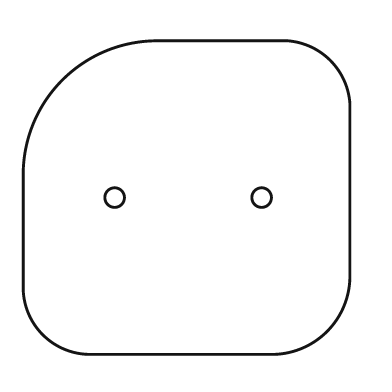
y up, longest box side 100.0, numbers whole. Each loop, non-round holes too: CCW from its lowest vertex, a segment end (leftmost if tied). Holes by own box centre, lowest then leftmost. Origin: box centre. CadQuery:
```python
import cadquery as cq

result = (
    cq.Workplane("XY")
    .moveTo(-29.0, -48.0)
    .lineTo(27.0, -48.0)
    .threePointArc((43.0, -41.0), (50.0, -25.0))
    .lineTo(50.0, 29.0)
    .threePointArc((44.0, 42.0), (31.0, 48.0))
    .lineTo(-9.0, 48.0)
    .threePointArc((-38.0, 36.0), (-50.0, 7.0))
    .lineTo(-50.0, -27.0)
    .threePointArc((-44.0, -42.0), (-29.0, -48.0))
    .close()
    .moveTo(-22.0, 0.0)
    .circle(3.0)
    .moveTo(23.0, 0.0)
    .circle(3.0)
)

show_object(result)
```